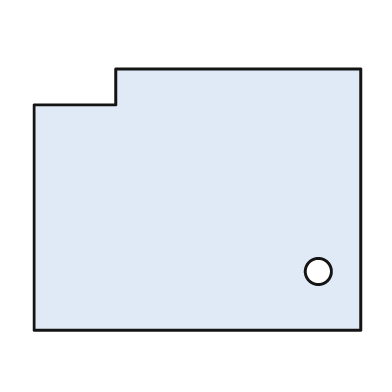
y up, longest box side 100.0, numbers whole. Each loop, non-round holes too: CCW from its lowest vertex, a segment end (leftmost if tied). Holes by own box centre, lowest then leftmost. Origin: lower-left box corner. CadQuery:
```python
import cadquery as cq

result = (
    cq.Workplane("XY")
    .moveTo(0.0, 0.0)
    .lineTo(100.0, 0.0)
    .lineTo(100.0, 80.0)
    .lineTo(25.0, 80.0)
    .lineTo(25.0, 69.0)
    .lineTo(0.0, 69.0)
    .close()
    .moveTo(87.0, 18.0)
    .circle(4.0)
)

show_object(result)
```